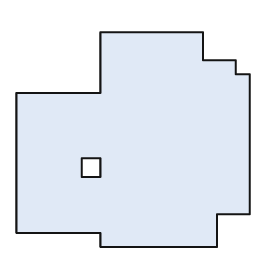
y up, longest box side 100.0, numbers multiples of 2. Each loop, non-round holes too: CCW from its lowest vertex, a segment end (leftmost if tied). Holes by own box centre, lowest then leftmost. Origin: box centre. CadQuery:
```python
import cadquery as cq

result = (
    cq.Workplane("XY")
    .moveTo(-14.0, -46.0)
    .lineTo(36.0, -46.0)
    .lineTo(36.0, -32.0)
    .lineTo(50.0, -32.0)
    .lineTo(50.0, 28.0)
    .lineTo(44.0, 28.0)
    .lineTo(44.0, 34.0)
    .lineTo(30.0, 34.0)
    .lineTo(30.0, 46.0)
    .lineTo(-14.0, 46.0)
    .lineTo(-14.0, 20.0)
    .lineTo(-50.0, 20.0)
    .lineTo(-50.0, -40.0)
    .lineTo(-14.0, -40.0)
    .close()
    .moveTo(-22.0, -16.0)
    .lineTo(-14.0, -16.0)
    .lineTo(-14.0, -8.0)
    .lineTo(-22.0, -8.0)
    .close()
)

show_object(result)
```